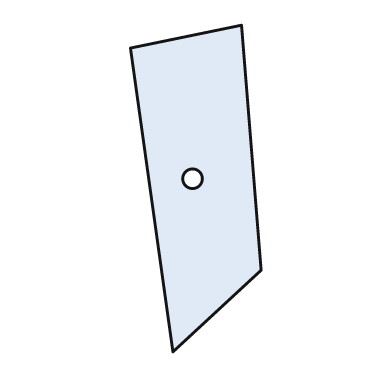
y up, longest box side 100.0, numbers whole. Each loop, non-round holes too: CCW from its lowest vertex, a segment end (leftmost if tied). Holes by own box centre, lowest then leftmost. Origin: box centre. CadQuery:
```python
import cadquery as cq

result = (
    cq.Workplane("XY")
    .moveTo(-7.0, -50.0)
    .lineTo(20.0, -25.0)
    .lineTo(14.0, 50.0)
    .lineTo(-20.0, 43.0)
    .close()
    .moveTo(-1.0, 3.0)
    .circle(3.0)
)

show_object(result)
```